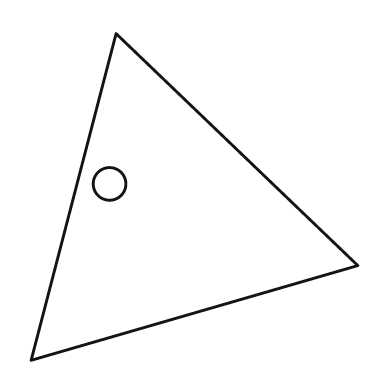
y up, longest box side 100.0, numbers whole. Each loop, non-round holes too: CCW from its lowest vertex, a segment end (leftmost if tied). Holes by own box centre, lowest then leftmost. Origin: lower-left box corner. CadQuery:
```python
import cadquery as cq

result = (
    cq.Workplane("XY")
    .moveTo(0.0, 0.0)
    .lineTo(100.0, 29.0)
    .lineTo(26.0, 100.0)
    .close()
    .moveTo(24.0, 54.0)
    .circle(5.0)
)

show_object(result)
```